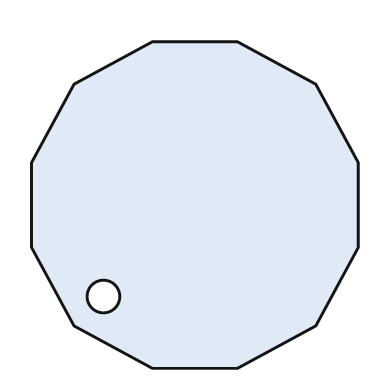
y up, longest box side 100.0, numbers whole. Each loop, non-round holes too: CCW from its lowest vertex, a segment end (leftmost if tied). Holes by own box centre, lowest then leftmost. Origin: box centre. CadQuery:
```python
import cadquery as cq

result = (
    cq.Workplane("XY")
    .moveTo(-13.0, -50.0)
    .lineTo(13.0, -50.0)
    .lineTo(37.0, -37.0)
    .lineTo(50.0, -13.0)
    .lineTo(50.0, 13.0)
    .lineTo(37.0, 37.0)
    .lineTo(13.0, 50.0)
    .lineTo(-13.0, 50.0)
    .lineTo(-37.0, 37.0)
    .lineTo(-50.0, 13.0)
    .lineTo(-50.0, -13.0)
    .lineTo(-37.0, -37.0)
    .close()
    .moveTo(-28.0, -28.0)
    .circle(5.0)
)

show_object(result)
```